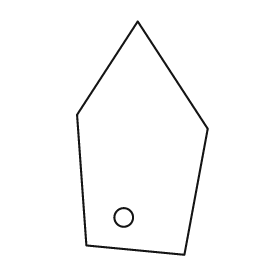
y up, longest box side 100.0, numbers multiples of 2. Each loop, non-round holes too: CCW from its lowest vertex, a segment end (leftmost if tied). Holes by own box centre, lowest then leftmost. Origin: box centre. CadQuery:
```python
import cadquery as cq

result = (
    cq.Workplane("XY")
    .moveTo(18.0, -50.0)
    .lineTo(28.0, 4.0)
    .lineTo(-2.0, 50.0)
    .lineTo(-28.0, 10.0)
    .lineTo(-24.0, -46.0)
    .close()
    .moveTo(-8.0, -34.0)
    .circle(4.0)
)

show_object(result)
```